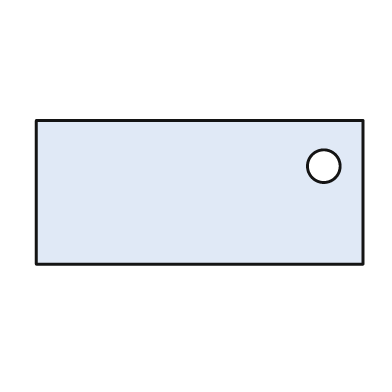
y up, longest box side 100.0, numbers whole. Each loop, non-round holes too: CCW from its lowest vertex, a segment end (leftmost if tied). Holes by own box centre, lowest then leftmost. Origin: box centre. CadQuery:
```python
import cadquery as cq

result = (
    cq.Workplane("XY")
    .moveTo(-50.0, -22.0)
    .lineTo(50.0, -22.0)
    .lineTo(50.0, 22.0)
    .lineTo(-50.0, 22.0)
    .close()
    .moveTo(38.0, 8.0)
    .circle(5.0)
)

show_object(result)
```